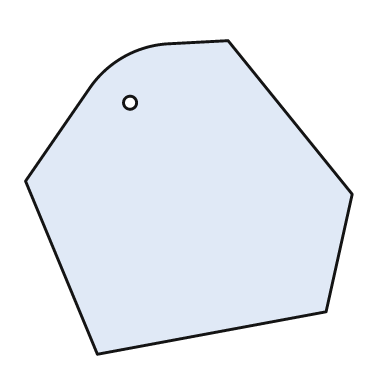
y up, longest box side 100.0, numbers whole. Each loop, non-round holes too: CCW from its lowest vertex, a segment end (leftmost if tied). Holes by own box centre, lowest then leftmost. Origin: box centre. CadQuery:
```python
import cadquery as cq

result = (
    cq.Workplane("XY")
    .moveTo(-28.0, -48.0)
    .lineTo(42.0, -35.0)
    .lineTo(50.0, 1.0)
    .lineTo(12.0, 48.0)
    .lineTo(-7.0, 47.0)
    .threePointArc((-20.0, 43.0), (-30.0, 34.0))
    .lineTo(-50.0, 5.0)
    .close()
    .moveTo(-18.0, 29.0)
    .circle(2.0)
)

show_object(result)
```